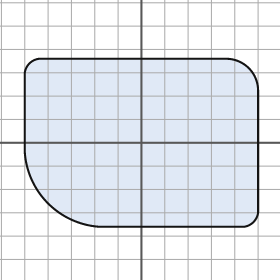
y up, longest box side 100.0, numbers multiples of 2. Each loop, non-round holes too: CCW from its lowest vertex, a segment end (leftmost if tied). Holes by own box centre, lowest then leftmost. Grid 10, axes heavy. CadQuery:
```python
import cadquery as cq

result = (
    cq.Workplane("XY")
    .moveTo(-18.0, -36.0)
    .lineTo(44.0, -36.0)
    .threePointArc((48.0, -34.0), (50.0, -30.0))
    .lineTo(50.0, 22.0)
    .threePointArc((46.0, 32.0), (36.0, 36.0))
    .lineTo(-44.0, 36.0)
    .threePointArc((-48.0, 34.0), (-50.0, 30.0))
    .lineTo(-50.0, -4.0)
    .threePointArc((-40.0, -26.0), (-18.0, -36.0))
    .close()
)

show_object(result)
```